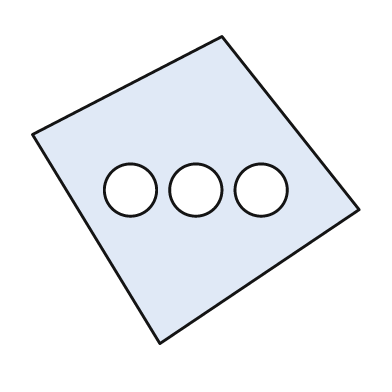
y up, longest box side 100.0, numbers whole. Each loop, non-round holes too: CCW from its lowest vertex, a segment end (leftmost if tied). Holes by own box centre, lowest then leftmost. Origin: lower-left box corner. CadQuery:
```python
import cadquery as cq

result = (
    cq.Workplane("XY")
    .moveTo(39.0, 0.0)
    .lineTo(100.0, 41.0)
    .lineTo(58.0, 94.0)
    .lineTo(0.0, 64.0)
    .close()
    .moveTo(30.0, 47.0)
    .circle(8.0)
    .moveTo(50.0, 47.0)
    .circle(8.0)
    .moveTo(70.0, 47.0)
    .circle(8.0)
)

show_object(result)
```